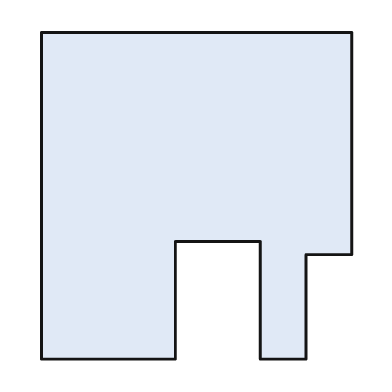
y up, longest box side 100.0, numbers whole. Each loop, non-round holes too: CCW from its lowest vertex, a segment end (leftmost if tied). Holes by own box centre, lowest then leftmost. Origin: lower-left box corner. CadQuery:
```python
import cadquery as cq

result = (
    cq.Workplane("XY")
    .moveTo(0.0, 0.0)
    .lineTo(41.0, 0.0)
    .lineTo(41.0, 36.0)
    .lineTo(67.0, 36.0)
    .lineTo(67.0, 0.0)
    .lineTo(81.0, 0.0)
    .lineTo(81.0, 32.0)
    .lineTo(95.0, 32.0)
    .lineTo(95.0, 100.0)
    .lineTo(0.0, 100.0)
    .close()
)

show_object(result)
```